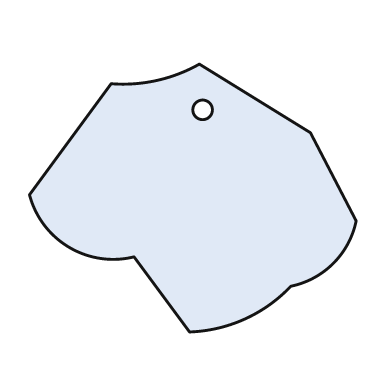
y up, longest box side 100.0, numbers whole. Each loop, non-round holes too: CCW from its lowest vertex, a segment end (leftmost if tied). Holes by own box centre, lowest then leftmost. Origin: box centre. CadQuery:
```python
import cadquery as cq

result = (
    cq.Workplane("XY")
    .moveTo(-1.0, -41.0)
    .threePointArc((16.0, -37.0), (30.0, -27.0))
    .threePointArc((43.0, -20.0), (50.0, -7.0))
    .lineTo(36.0, 20.0)
    .lineTo(2.0, 41.0)
    .threePointArc((-11.0, 36.0), (-25.0, 35.0))
    .lineTo(-50.0, 1.0)
    .threePointArc((-38.0, -15.0), (-18.0, -18.0))
    .close()
    .moveTo(3.0, 27.0)
    .circle(3.0)
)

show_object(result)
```